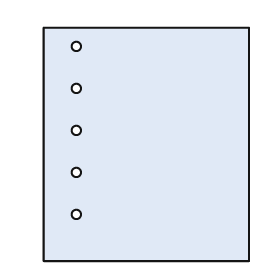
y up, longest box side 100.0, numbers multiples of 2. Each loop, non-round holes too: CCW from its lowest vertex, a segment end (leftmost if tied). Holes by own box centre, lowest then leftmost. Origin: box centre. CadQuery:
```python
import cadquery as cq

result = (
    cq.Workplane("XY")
    .moveTo(-44.0, -50.0)
    .lineTo(44.0, -50.0)
    .lineTo(44.0, 50.0)
    .lineTo(-44.0, 50.0)
    .close()
    .moveTo(-30.0, -30.0)
    .circle(2.0)
    .moveTo(-30.0, -12.0)
    .circle(2.0)
    .moveTo(-30.0, 6.0)
    .circle(2.0)
    .moveTo(-30.0, 24.0)
    .circle(2.0)
    .moveTo(-30.0, 42.0)
    .circle(2.0)
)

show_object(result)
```